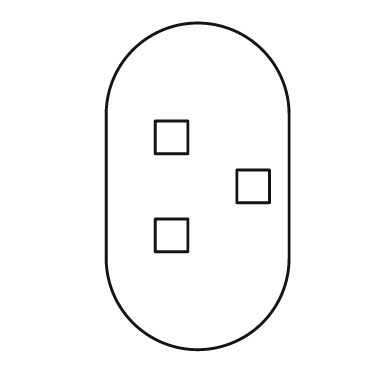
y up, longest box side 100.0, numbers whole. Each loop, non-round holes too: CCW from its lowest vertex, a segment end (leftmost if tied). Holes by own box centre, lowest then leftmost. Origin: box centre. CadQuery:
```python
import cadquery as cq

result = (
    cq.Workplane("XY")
    .moveTo(-28.0, -22.0)
    .threePointArc((0.0, -50.0), (28.0, -22.0))
    .lineTo(28.0, 22.0)
    .threePointArc((0.0, 50.0), (-28.0, 22.0))
    .close()
    .moveTo(-13.0, -20.0)
    .lineTo(-3.0, -20.0)
    .lineTo(-3.0, -10.0)
    .lineTo(-13.0, -10.0)
    .close()
    .moveTo(12.0, -5.0)
    .lineTo(22.0, -5.0)
    .lineTo(22.0, 5.0)
    .lineTo(12.0, 5.0)
    .close()
    .moveTo(-13.0, 10.0)
    .lineTo(-3.0, 10.0)
    .lineTo(-3.0, 20.0)
    .lineTo(-13.0, 20.0)
    .close()
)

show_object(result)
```